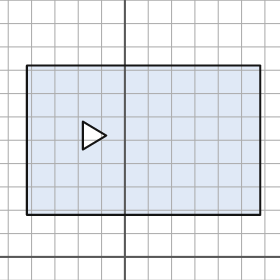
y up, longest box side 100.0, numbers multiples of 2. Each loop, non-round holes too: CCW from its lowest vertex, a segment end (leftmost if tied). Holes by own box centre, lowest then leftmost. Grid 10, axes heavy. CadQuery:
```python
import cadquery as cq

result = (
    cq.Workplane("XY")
    .moveTo(-42.0, 18.0)
    .lineTo(58.0, 18.0)
    .lineTo(58.0, 82.0)
    .lineTo(-42.0, 82.0)
    .close()
    .moveTo(-18.0, 46.0)
    .lineTo(-8.0, 52.0)
    .lineTo(-18.0, 58.0)
    .close()
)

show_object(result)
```